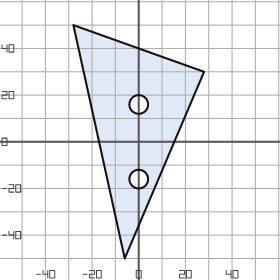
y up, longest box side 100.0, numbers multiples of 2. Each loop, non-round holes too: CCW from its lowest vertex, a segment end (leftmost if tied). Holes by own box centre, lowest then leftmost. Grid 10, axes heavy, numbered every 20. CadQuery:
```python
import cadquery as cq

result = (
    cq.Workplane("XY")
    .moveTo(-6.0, -50.0)
    .lineTo(28.0, 30.0)
    .lineTo(-28.0, 50.0)
    .close()
    .moveTo(0.0, -16.0)
    .circle(4.0)
    .moveTo(0.0, 16.0)
    .circle(4.0)
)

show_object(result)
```